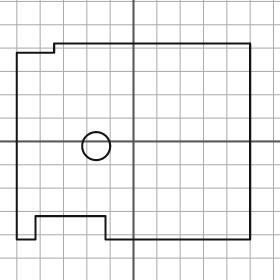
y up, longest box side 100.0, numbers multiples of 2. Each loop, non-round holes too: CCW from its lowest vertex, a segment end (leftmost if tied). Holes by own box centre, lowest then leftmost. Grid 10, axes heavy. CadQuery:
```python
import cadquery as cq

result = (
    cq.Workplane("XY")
    .moveTo(-50.0, -42.0)
    .lineTo(-42.0, -42.0)
    .lineTo(-42.0, -32.0)
    .lineTo(-12.0, -32.0)
    .lineTo(-12.0, -42.0)
    .lineTo(50.0, -42.0)
    .lineTo(50.0, 42.0)
    .lineTo(-34.0, 42.0)
    .lineTo(-34.0, 38.0)
    .lineTo(-50.0, 38.0)
    .close()
    .moveTo(-16.0, -2.0)
    .circle(6.0)
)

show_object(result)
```